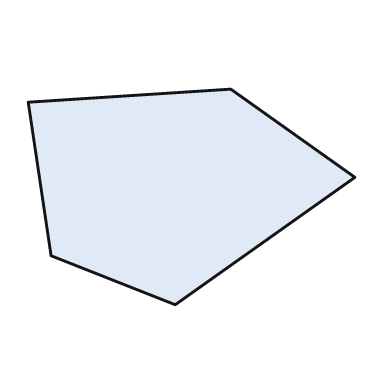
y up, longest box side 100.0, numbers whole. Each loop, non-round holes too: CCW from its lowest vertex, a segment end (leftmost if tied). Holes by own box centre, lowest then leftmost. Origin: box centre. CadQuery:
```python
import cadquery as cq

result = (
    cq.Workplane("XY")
    .moveTo(-5.0, -33.0)
    .lineTo(50.0, 6.0)
    .lineTo(12.0, 33.0)
    .lineTo(-50.0, 29.0)
    .lineTo(-43.0, -18.0)
    .close()
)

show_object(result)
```